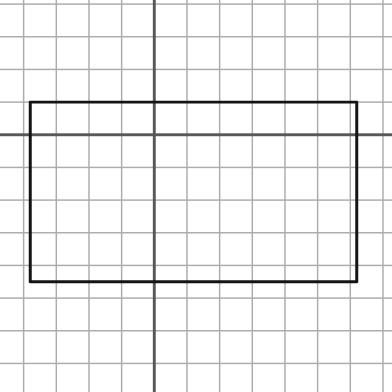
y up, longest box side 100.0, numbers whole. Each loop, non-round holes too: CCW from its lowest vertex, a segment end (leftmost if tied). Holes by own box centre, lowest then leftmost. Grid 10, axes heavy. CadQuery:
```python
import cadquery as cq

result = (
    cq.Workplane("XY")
    .moveTo(-38.0, -45.0)
    .lineTo(62.0, -45.0)
    .lineTo(62.0, 10.0)
    .lineTo(-38.0, 10.0)
    .close()
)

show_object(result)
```